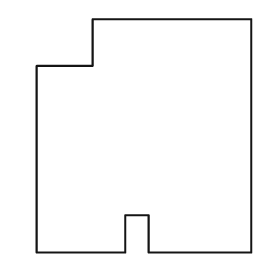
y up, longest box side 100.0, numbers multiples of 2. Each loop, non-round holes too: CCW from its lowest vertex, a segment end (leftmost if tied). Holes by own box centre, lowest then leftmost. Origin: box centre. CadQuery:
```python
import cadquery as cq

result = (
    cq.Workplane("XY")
    .moveTo(-46.0, -50.0)
    .lineTo(-8.0, -50.0)
    .lineTo(-8.0, -34.0)
    .lineTo(2.0, -34.0)
    .lineTo(2.0, -50.0)
    .lineTo(46.0, -50.0)
    .lineTo(46.0, 50.0)
    .lineTo(-22.0, 50.0)
    .lineTo(-22.0, 30.0)
    .lineTo(-46.0, 30.0)
    .close()
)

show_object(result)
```